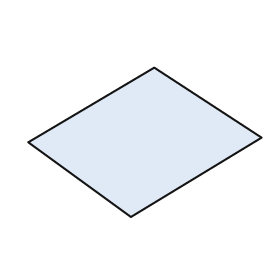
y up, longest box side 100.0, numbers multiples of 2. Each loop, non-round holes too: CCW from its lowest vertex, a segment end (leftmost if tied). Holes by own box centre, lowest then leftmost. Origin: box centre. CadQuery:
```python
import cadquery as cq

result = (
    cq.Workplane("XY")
    .moveTo(-6.0, -32.0)
    .lineTo(50.0, 2.0)
    .lineTo(4.0, 32.0)
    .lineTo(-50.0, 0.0)
    .close()
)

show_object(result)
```